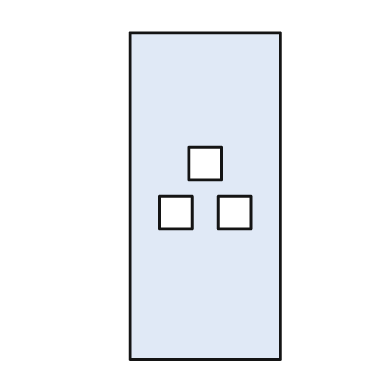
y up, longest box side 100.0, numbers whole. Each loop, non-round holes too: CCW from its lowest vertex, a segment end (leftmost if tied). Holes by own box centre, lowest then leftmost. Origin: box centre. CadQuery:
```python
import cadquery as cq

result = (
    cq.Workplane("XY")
    .moveTo(-23.0, -50.0)
    .lineTo(23.0, -50.0)
    .lineTo(23.0, 50.0)
    .lineTo(-23.0, 50.0)
    .close()
    .moveTo(-14.0, -10.0)
    .lineTo(-4.0, -10.0)
    .lineTo(-4.0, 0.0)
    .lineTo(-14.0, 0.0)
    .close()
    .moveTo(4.0, -10.0)
    .lineTo(14.0, -10.0)
    .lineTo(14.0, 0.0)
    .lineTo(4.0, 0.0)
    .close()
    .moveTo(-5.0, 5.0)
    .lineTo(5.0, 5.0)
    .lineTo(5.0, 15.0)
    .lineTo(-5.0, 15.0)
    .close()
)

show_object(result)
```